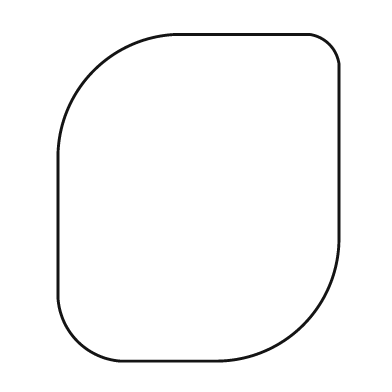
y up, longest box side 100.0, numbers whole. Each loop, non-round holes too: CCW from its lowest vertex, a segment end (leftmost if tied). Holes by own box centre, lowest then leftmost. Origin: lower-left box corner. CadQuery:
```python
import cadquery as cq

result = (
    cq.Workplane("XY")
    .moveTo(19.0, 0.0)
    .lineTo(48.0, 0.0)
    .threePointArc((75.0, 11.0), (86.0, 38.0))
    .lineTo(86.0, 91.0)
    .threePointArc((83.0, 97.0), (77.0, 100.0))
    .lineTo(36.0, 100.0)
    .threePointArc((11.0, 89.0), (0.0, 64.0))
    .lineTo(0.0, 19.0)
    .threePointArc((6.0, 6.0), (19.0, 0.0))
    .close()
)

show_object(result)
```